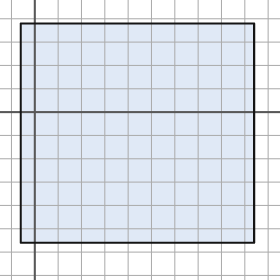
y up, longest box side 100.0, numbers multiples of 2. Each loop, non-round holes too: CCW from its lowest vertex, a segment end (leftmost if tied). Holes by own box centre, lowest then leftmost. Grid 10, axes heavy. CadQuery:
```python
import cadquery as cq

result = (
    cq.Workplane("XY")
    .moveTo(-6.0, -56.0)
    .lineTo(94.0, -56.0)
    .lineTo(94.0, 38.0)
    .lineTo(-6.0, 38.0)
    .close()
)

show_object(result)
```